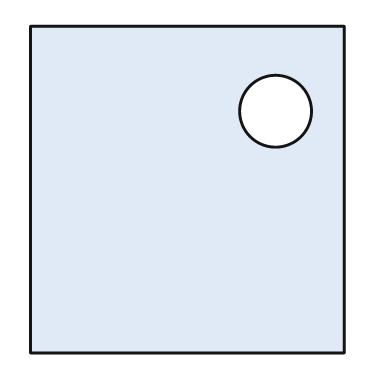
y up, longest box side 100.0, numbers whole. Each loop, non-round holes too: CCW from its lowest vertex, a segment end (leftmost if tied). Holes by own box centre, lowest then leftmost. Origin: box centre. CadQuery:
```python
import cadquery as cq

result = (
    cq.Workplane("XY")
    .moveTo(-48.0, -50.0)
    .lineTo(48.0, -50.0)
    .lineTo(48.0, 50.0)
    .lineTo(-48.0, 50.0)
    .close()
    .moveTo(27.0, 24.0)
    .circle(11.0)
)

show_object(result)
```